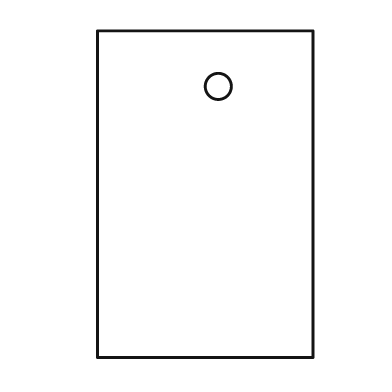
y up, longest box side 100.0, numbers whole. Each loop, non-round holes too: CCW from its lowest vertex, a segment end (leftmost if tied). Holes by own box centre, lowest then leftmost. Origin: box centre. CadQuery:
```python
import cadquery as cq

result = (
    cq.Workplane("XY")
    .moveTo(-33.0, -50.0)
    .lineTo(33.0, -50.0)
    .lineTo(33.0, 50.0)
    .lineTo(-33.0, 50.0)
    .close()
    .moveTo(4.0, 33.0)
    .circle(4.0)
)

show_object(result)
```